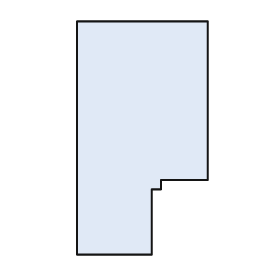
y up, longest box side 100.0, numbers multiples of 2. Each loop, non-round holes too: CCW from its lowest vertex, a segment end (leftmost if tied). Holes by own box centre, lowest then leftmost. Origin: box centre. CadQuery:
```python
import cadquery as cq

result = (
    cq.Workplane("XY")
    .moveTo(-28.0, -50.0)
    .lineTo(4.0, -50.0)
    .lineTo(4.0, -22.0)
    .lineTo(8.0, -22.0)
    .lineTo(8.0, -18.0)
    .lineTo(28.0, -18.0)
    .lineTo(28.0, 50.0)
    .lineTo(-28.0, 50.0)
    .close()
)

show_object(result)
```